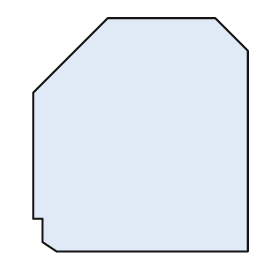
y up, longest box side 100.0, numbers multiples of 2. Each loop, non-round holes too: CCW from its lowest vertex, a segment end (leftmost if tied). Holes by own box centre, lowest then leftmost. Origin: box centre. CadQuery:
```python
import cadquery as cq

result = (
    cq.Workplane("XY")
    .moveTo(-36.0, -50.0)
    .lineTo(46.0, -50.0)
    .lineTo(46.0, 36.0)
    .lineTo(32.0, 50.0)
    .lineTo(-14.0, 50.0)
    .lineTo(-46.0, 18.0)
    .lineTo(-46.0, -36.0)
    .lineTo(-42.0, -36.0)
    .lineTo(-42.0, -46.0)
    .close()
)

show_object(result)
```